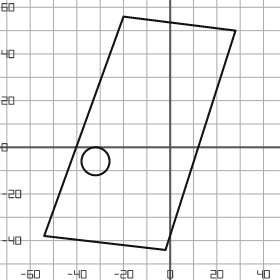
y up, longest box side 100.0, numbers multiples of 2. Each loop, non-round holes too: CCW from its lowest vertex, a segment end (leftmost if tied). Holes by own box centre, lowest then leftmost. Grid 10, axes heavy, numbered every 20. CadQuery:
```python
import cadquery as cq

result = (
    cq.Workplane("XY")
    .moveTo(-2.0, -44.0)
    .lineTo(28.0, 50.0)
    .lineTo(-20.0, 56.0)
    .lineTo(-54.0, -38.0)
    .close()
    .moveTo(-32.0, -6.0)
    .circle(6.0)
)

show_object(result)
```